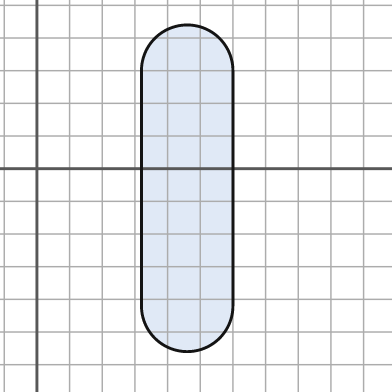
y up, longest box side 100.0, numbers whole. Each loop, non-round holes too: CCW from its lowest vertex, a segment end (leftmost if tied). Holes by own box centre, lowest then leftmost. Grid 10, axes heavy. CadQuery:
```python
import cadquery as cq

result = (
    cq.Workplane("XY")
    .moveTo(32.0, -42.0)
    .threePointArc((46.0, -56.0), (60.0, -42.0))
    .lineTo(60.0, 30.0)
    .threePointArc((46.0, 44.0), (32.0, 30.0))
    .close()
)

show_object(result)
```